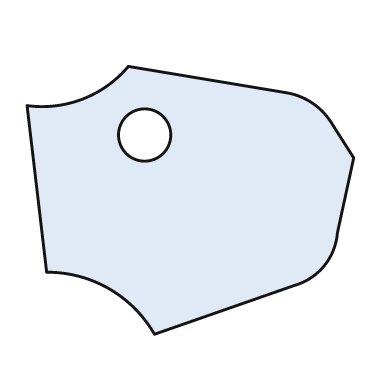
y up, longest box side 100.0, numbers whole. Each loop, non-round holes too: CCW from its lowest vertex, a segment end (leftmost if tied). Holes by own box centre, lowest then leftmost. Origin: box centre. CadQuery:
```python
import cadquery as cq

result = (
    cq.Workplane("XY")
    .moveTo(-11.0, -41.0)
    .lineTo(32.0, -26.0)
    .threePointArc((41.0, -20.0), (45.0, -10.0))
    .lineTo(50.0, 13.0)
    .lineTo(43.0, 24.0)
    .threePointArc((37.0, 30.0), (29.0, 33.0))
    .lineTo(-19.0, 41.0)
    .threePointArc((-33.0, 31.0), (-50.0, 29.0))
    .lineTo(-44.0, -22.0)
    .threePointArc((-25.0, -27.0), (-11.0, -41.0))
    .close()
    .moveTo(-14.0, 20.0)
    .circle(8.0)
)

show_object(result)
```